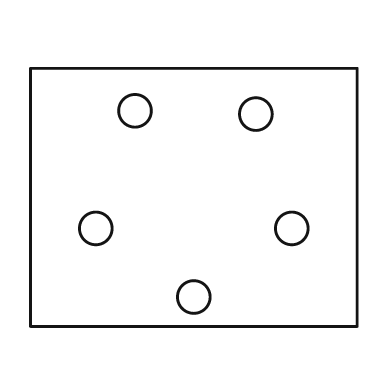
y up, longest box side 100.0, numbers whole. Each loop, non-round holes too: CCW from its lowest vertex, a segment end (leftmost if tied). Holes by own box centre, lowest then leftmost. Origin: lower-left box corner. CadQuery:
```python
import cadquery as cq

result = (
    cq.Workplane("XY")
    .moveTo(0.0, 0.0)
    .lineTo(100.0, 0.0)
    .lineTo(100.0, 79.0)
    .lineTo(0.0, 79.0)
    .close()
    .moveTo(50.0, 9.0)
    .circle(5.0)
    .moveTo(20.0, 30.0)
    .circle(5.0)
    .moveTo(80.0, 30.0)
    .circle(5.0)
    .moveTo(69.0, 65.0)
    .circle(5.0)
    .moveTo(32.0, 66.0)
    .circle(5.0)
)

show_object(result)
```